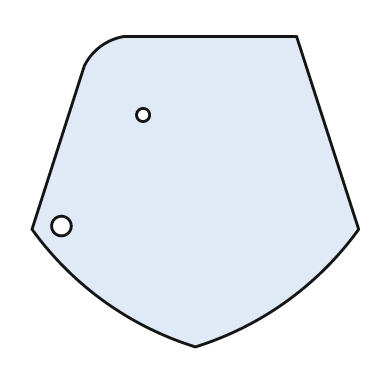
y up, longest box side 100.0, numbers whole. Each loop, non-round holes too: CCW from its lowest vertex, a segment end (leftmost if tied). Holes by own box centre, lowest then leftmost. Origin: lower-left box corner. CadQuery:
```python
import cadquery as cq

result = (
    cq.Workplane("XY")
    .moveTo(50.0, 0.0)
    .threePointArc((78.0, 14.0), (100.0, 36.0))
    .lineTo(81.0, 95.0)
    .lineTo(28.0, 95.0)
    .threePointArc((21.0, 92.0), (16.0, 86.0))
    .lineTo(0.0, 36.0)
    .threePointArc((22.0, 14.0), (50.0, 0.0))
    .close()
    .moveTo(9.0, 37.0)
    .circle(3.0)
    .moveTo(34.0, 71.0)
    .circle(2.0)
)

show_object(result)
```